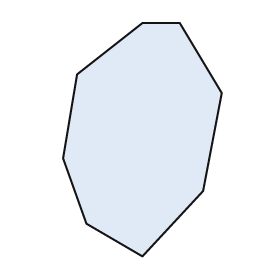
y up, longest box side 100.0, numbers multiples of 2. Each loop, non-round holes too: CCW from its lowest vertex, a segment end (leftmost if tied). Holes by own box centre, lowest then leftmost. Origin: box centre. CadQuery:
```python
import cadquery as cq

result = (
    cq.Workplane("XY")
    .moveTo(0.0, -50.0)
    .lineTo(26.0, -22.0)
    .lineTo(34.0, 20.0)
    .lineTo(16.0, 50.0)
    .lineTo(0.0, 50.0)
    .lineTo(-28.0, 28.0)
    .lineTo(-34.0, -8.0)
    .lineTo(-24.0, -36.0)
    .close()
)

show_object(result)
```